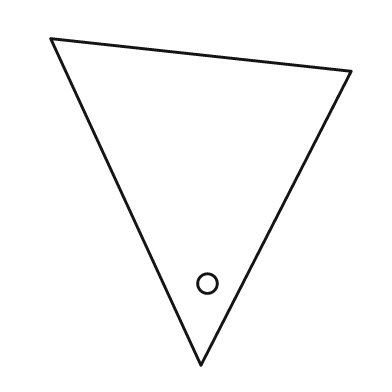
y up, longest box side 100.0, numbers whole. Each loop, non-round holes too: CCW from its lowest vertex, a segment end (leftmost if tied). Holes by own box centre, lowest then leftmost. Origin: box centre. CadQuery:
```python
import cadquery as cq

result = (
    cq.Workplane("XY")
    .moveTo(0.0, -50.0)
    .lineTo(46.0, 40.0)
    .lineTo(-46.0, 50.0)
    .close()
    .moveTo(2.0, -25.0)
    .circle(3.0)
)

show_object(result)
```